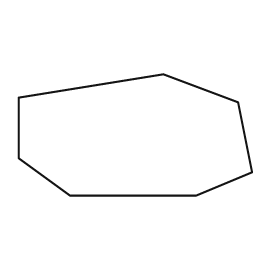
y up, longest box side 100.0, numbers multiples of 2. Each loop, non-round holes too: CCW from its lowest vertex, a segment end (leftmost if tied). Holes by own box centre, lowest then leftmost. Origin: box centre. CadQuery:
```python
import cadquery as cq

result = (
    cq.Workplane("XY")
    .moveTo(-28.0, -26.0)
    .lineTo(26.0, -26.0)
    .lineTo(50.0, -16.0)
    .lineTo(44.0, 14.0)
    .lineTo(12.0, 26.0)
    .lineTo(-50.0, 16.0)
    .lineTo(-50.0, -10.0)
    .close()
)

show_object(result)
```